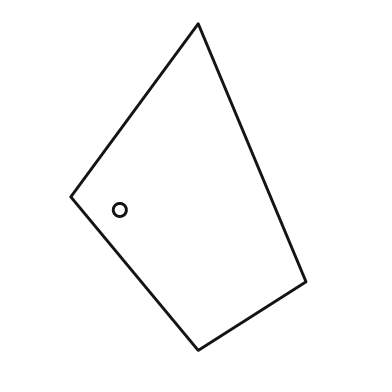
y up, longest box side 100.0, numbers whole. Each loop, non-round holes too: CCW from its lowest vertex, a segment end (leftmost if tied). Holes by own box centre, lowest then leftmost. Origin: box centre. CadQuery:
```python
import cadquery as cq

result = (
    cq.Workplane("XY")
    .moveTo(3.0, -50.0)
    .lineTo(36.0, -29.0)
    .lineTo(3.0, 50.0)
    .lineTo(-36.0, -3.0)
    .close()
    .moveTo(-21.0, -7.0)
    .circle(2.0)
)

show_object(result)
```